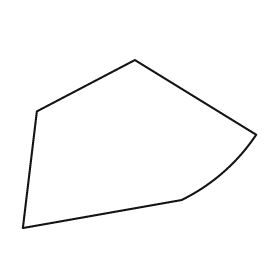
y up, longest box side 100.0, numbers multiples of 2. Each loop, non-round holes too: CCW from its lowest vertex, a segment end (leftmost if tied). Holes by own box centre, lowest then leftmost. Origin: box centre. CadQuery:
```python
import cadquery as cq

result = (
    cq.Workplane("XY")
    .moveTo(-50.0, -36.0)
    .lineTo(18.0, -24.0)
    .threePointArc((36.0, -12.0), (50.0, 4.0))
    .lineTo(-2.0, 36.0)
    .lineTo(-44.0, 14.0)
    .close()
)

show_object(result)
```